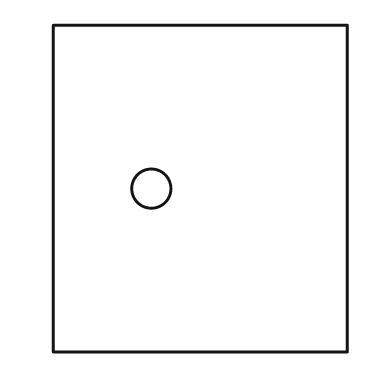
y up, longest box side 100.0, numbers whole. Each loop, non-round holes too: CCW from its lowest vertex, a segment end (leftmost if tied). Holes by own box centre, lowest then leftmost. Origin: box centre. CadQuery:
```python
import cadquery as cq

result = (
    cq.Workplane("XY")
    .moveTo(-45.0, -50.0)
    .lineTo(45.0, -50.0)
    .lineTo(45.0, 50.0)
    .lineTo(-45.0, 50.0)
    .close()
    .moveTo(-15.0, 0.0)
    .circle(6.0)
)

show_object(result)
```